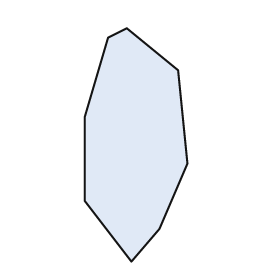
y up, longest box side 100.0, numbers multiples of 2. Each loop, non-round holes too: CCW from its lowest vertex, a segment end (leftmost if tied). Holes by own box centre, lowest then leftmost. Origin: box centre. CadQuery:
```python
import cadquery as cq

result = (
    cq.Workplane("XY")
    .moveTo(-2.0, -50.0)
    .lineTo(10.0, -36.0)
    .lineTo(22.0, -8.0)
    .lineTo(18.0, 32.0)
    .lineTo(-4.0, 50.0)
    .lineTo(-12.0, 46.0)
    .lineTo(-22.0, 12.0)
    .lineTo(-22.0, -24.0)
    .close()
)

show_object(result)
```